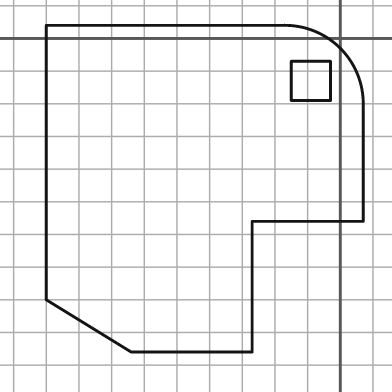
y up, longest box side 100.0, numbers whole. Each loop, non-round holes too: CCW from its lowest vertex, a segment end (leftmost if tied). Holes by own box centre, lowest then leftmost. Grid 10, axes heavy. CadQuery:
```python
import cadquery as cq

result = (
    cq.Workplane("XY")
    .moveTo(-64.0, -96.0)
    .lineTo(-27.0, -96.0)
    .lineTo(-27.0, -56.0)
    .lineTo(7.0, -56.0)
    .lineTo(7.0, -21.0)
    .threePointArc((0.0, -3.0), (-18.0, 4.0))
    .lineTo(-90.0, 4.0)
    .lineTo(-90.0, -80.0)
    .close()
    .moveTo(-15.0, -19.0)
    .lineTo(-3.0, -19.0)
    .lineTo(-3.0, -7.0)
    .lineTo(-15.0, -7.0)
    .close()
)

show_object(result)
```